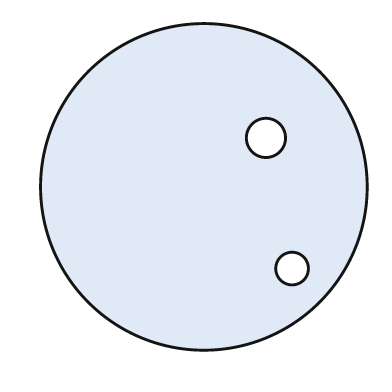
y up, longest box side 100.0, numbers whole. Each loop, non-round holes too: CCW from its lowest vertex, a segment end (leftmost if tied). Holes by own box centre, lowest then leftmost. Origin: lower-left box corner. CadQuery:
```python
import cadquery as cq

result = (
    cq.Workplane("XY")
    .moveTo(50.0, 50.0)
    .circle(50.0)
    .moveTo(77.0, 25.0)
    .circle(5.0)
    .moveTo(69.0, 65.0)
    .circle(6.0)
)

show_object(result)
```